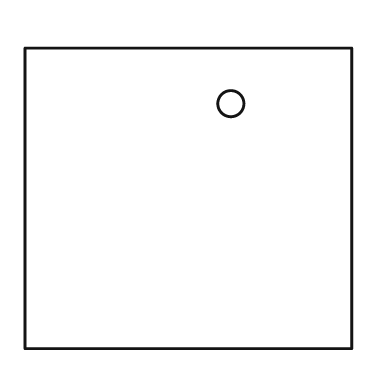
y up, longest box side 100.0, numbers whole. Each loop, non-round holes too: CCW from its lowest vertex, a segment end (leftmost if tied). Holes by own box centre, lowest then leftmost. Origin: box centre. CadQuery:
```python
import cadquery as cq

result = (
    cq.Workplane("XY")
    .moveTo(-50.0, -46.0)
    .lineTo(50.0, -46.0)
    .lineTo(50.0, 46.0)
    .lineTo(-50.0, 46.0)
    .close()
    .moveTo(13.0, 29.0)
    .circle(4.0)
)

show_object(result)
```